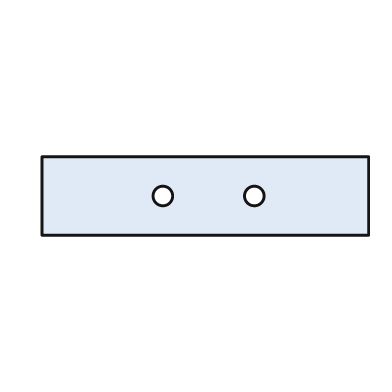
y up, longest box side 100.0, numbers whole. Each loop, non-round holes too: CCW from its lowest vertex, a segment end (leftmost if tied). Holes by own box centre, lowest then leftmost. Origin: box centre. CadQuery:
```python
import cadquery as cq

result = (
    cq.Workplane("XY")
    .moveTo(-50.0, -12.0)
    .lineTo(50.0, -12.0)
    .lineTo(50.0, 12.0)
    .lineTo(-50.0, 12.0)
    .close()
    .moveTo(-13.0, 0.0)
    .circle(3.0)
    .moveTo(15.0, 0.0)
    .circle(3.0)
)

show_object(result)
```